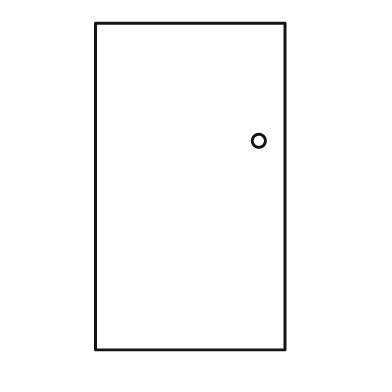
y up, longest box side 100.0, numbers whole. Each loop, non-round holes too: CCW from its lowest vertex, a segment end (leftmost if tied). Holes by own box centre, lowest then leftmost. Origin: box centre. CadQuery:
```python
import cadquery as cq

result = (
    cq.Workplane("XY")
    .moveTo(-29.0, -50.0)
    .lineTo(29.0, -50.0)
    .lineTo(29.0, 50.0)
    .lineTo(-29.0, 50.0)
    .close()
    .moveTo(21.0, 14.0)
    .circle(2.0)
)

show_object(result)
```